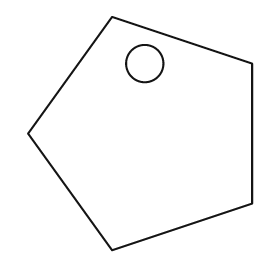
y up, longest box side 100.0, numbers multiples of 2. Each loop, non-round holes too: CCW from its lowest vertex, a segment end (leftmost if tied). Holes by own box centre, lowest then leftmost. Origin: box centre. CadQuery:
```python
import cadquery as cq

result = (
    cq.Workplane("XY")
    .moveTo(-12.0, -50.0)
    .lineTo(48.0, -30.0)
    .lineTo(48.0, 30.0)
    .lineTo(-12.0, 50.0)
    .lineTo(-48.0, 0.0)
    .close()
    .moveTo(2.0, 30.0)
    .circle(8.0)
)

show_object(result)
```